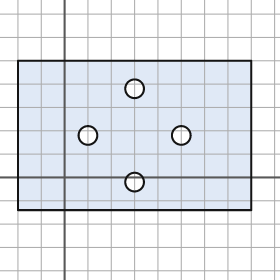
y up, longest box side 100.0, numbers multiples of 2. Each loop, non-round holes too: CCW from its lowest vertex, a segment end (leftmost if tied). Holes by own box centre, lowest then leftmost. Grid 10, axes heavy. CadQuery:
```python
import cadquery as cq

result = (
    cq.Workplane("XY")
    .moveTo(-20.0, -14.0)
    .lineTo(80.0, -14.0)
    .lineTo(80.0, 50.0)
    .lineTo(-20.0, 50.0)
    .close()
    .moveTo(30.0, -2.0)
    .circle(4.0)
    .moveTo(10.0, 18.0)
    .circle(4.0)
    .moveTo(50.0, 18.0)
    .circle(4.0)
    .moveTo(30.0, 38.0)
    .circle(4.0)
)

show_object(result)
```